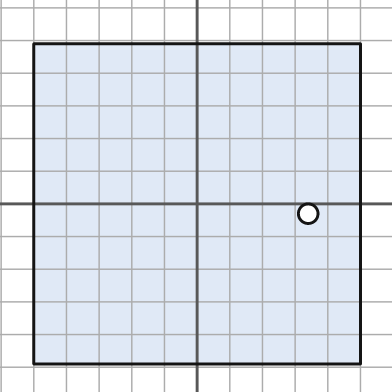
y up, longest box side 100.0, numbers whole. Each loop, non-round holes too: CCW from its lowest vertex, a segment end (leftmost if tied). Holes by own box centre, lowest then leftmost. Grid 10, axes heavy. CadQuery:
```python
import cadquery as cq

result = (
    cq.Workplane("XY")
    .moveTo(-50.0, -49.0)
    .lineTo(50.0, -49.0)
    .lineTo(50.0, 49.0)
    .lineTo(-50.0, 49.0)
    .close()
    .moveTo(34.0, -3.0)
    .circle(3.0)
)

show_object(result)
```